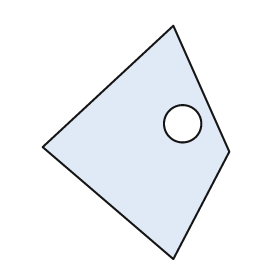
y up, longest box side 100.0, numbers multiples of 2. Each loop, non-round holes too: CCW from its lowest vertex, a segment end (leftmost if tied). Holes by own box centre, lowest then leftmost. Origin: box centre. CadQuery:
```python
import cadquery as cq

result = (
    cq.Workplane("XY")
    .moveTo(16.0, -50.0)
    .lineTo(40.0, -4.0)
    .lineTo(16.0, 50.0)
    .lineTo(-40.0, -2.0)
    .close()
    .moveTo(20.0, 8.0)
    .circle(8.0)
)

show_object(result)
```